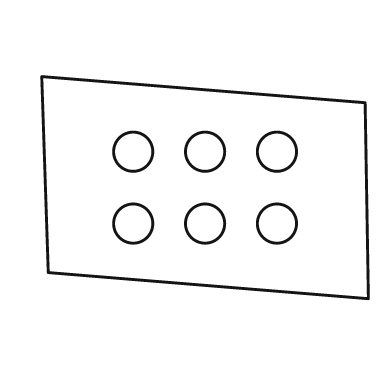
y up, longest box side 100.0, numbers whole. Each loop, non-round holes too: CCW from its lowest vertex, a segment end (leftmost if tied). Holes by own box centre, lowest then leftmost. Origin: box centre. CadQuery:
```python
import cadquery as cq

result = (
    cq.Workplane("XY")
    .moveTo(50.0, -34.0)
    .lineTo(49.0, 26.0)
    .lineTo(-50.0, 34.0)
    .lineTo(-48.0, -26.0)
    .close()
    .moveTo(-22.0, -11.0)
    .circle(6.0)
    .moveTo(0.0, -11.0)
    .circle(6.0)
    .moveTo(22.0, -11.0)
    .circle(6.0)
    .moveTo(-22.0, 11.0)
    .circle(6.0)
    .moveTo(0.0, 11.0)
    .circle(6.0)
    .moveTo(22.0, 11.0)
    .circle(6.0)
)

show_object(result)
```